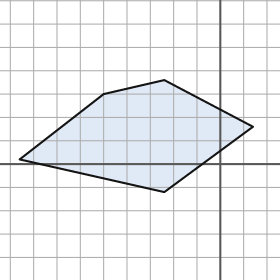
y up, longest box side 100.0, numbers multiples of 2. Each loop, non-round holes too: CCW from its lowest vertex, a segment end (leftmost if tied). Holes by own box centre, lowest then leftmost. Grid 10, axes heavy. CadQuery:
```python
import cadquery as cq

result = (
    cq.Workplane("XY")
    .moveTo(-24.0, -12.0)
    .lineTo(14.0, 16.0)
    .lineTo(-24.0, 36.0)
    .lineTo(-50.0, 30.0)
    .lineTo(-86.0, 2.0)
    .close()
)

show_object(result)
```